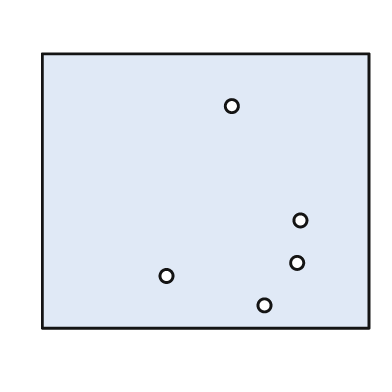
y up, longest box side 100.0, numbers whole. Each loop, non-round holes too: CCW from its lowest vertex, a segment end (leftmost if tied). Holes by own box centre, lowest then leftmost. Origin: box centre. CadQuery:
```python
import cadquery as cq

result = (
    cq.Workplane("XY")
    .moveTo(-50.0, -42.0)
    .lineTo(50.0, -42.0)
    .lineTo(50.0, 42.0)
    .lineTo(-50.0, 42.0)
    .close()
    .moveTo(18.0, -35.0)
    .circle(2.0)
    .moveTo(-12.0, -26.0)
    .circle(2.0)
    .moveTo(28.0, -22.0)
    .circle(2.0)
    .moveTo(29.0, -9.0)
    .circle(2.0)
    .moveTo(8.0, 26.0)
    .circle(2.0)
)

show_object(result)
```